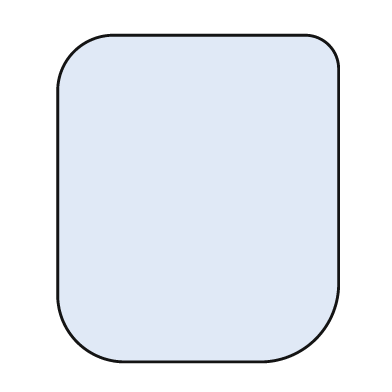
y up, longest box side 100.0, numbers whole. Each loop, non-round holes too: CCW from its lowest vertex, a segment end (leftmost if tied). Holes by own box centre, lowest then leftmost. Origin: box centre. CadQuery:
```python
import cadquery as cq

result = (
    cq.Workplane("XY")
    .moveTo(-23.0, -50.0)
    .lineTo(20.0, -50.0)
    .threePointArc((36.0, -43.0), (43.0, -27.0))
    .lineTo(43.0, 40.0)
    .threePointArc((40.0, 47.0), (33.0, 50.0))
    .lineTo(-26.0, 50.0)
    .threePointArc((-38.0, 45.0), (-43.0, 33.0))
    .lineTo(-43.0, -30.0)
    .threePointArc((-37.0, -44.0), (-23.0, -50.0))
    .close()
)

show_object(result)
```